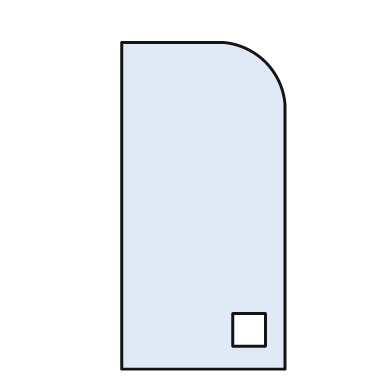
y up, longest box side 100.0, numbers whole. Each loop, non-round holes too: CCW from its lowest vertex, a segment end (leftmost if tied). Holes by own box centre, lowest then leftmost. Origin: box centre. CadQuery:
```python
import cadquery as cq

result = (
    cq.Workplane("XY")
    .moveTo(-25.0, -50.0)
    .lineTo(25.0, -50.0)
    .lineTo(25.0, 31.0)
    .threePointArc((19.0, 44.0), (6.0, 50.0))
    .lineTo(-25.0, 50.0)
    .close()
    .moveTo(9.0, -43.0)
    .lineTo(19.0, -43.0)
    .lineTo(19.0, -33.0)
    .lineTo(9.0, -33.0)
    .close()
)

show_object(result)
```